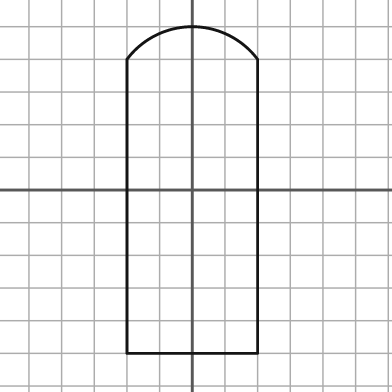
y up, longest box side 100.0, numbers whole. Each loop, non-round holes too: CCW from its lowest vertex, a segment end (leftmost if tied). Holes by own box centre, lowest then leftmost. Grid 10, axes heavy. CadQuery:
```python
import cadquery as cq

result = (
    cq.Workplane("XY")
    .moveTo(-20.0, -50.0)
    .lineTo(20.0, -50.0)
    .lineTo(20.0, 40.0)
    .threePointArc((0.0, 50.0), (-20.0, 40.0))
    .close()
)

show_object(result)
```